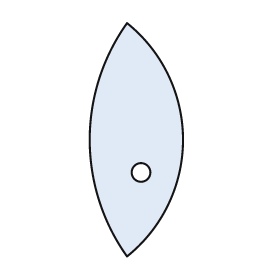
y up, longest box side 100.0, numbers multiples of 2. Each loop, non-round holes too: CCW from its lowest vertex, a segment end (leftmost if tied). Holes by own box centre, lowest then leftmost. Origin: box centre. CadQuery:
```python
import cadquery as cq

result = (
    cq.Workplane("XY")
    .moveTo(-4.0, -50.0)
    .threePointArc((20.0, 0.0), (-4.0, 50.0))
    .threePointArc((-20.0, 0.0), (-4.0, -50.0))
    .close()
    .moveTo(2.0, -14.0)
    .circle(4.0)
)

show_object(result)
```